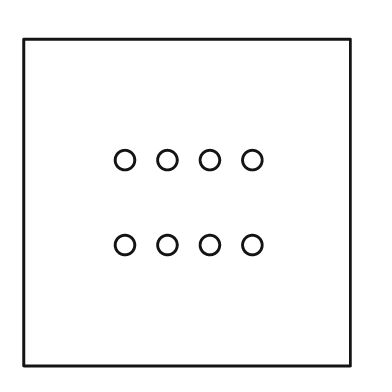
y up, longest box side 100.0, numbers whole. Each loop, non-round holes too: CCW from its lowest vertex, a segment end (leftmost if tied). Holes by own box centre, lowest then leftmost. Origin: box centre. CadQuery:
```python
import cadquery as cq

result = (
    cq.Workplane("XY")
    .moveTo(-50.0, -50.0)
    .lineTo(50.0, -50.0)
    .lineTo(50.0, 50.0)
    .lineTo(-50.0, 50.0)
    .close()
    .moveTo(-19.0, -13.0)
    .circle(3.0)
    .moveTo(-6.0, -13.0)
    .circle(3.0)
    .moveTo(7.0, -13.0)
    .circle(3.0)
    .moveTo(20.0, -13.0)
    .circle(3.0)
    .moveTo(-19.0, 13.0)
    .circle(3.0)
    .moveTo(-6.0, 13.0)
    .circle(3.0)
    .moveTo(7.0, 13.0)
    .circle(3.0)
    .moveTo(20.0, 13.0)
    .circle(3.0)
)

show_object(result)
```